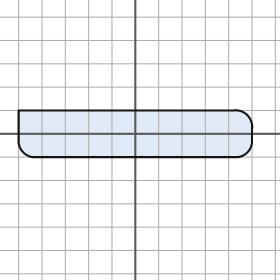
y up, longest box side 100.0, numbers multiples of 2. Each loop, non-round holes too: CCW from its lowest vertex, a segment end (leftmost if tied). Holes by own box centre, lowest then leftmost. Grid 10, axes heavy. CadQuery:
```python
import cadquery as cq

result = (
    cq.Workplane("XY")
    .moveTo(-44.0, -10.0)
    .lineTo(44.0, -10.0)
    .threePointArc((48.0, -8.0), (50.0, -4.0))
    .lineTo(50.0, 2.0)
    .threePointArc((48.0, 8.0), (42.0, 10.0))
    .lineTo(-50.0, 10.0)
    .lineTo(-50.0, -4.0)
    .threePointArc((-48.0, -8.0), (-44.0, -10.0))
    .close()
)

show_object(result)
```